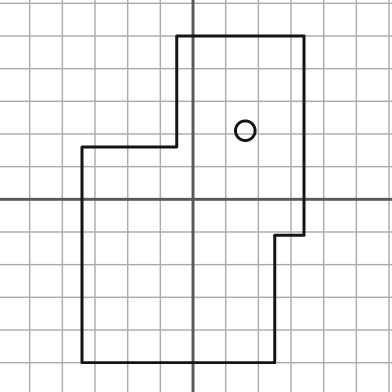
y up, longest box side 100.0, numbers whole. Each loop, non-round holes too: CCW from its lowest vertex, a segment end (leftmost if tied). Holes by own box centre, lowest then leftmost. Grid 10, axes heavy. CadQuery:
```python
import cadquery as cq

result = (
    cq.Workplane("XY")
    .moveTo(-34.0, -50.0)
    .lineTo(25.0, -50.0)
    .lineTo(25.0, -11.0)
    .lineTo(34.0, -11.0)
    .lineTo(34.0, 50.0)
    .lineTo(-5.0, 50.0)
    .lineTo(-5.0, 16.0)
    .lineTo(-34.0, 16.0)
    .close()
    .moveTo(16.0, 21.0)
    .circle(3.0)
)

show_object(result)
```